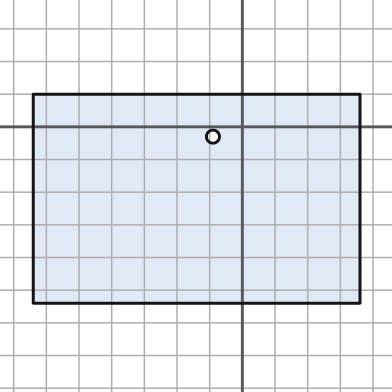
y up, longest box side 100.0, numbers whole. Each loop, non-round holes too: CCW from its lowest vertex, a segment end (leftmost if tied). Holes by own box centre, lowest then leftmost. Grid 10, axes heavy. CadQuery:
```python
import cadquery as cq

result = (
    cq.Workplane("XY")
    .moveTo(-64.0, -54.0)
    .lineTo(36.0, -54.0)
    .lineTo(36.0, 10.0)
    .lineTo(-64.0, 10.0)
    .close()
    .moveTo(-9.0, -3.0)
    .circle(2.0)
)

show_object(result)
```